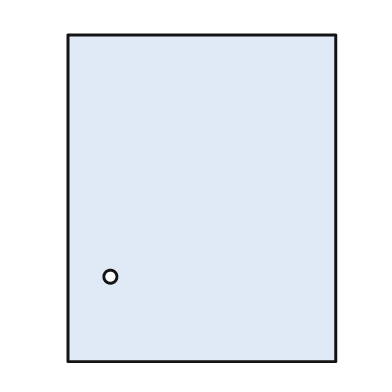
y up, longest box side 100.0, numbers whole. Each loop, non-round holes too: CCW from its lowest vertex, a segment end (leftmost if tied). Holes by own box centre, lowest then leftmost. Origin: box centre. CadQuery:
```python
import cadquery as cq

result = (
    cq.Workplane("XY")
    .moveTo(-41.0, -50.0)
    .lineTo(41.0, -50.0)
    .lineTo(41.0, 50.0)
    .lineTo(-41.0, 50.0)
    .close()
    .moveTo(-28.0, -24.0)
    .circle(2.0)
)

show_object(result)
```